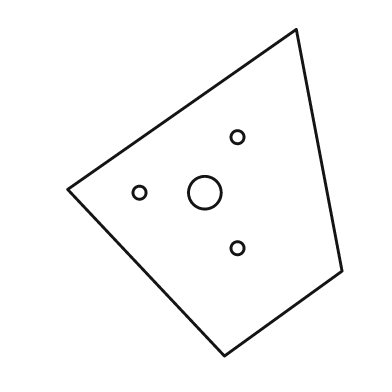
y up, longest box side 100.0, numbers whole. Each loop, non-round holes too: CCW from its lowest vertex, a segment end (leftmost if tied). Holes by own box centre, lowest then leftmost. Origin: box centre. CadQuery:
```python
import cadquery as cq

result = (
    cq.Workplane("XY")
    .moveTo(6.0, -50.0)
    .lineTo(42.0, -24.0)
    .lineTo(28.0, 50.0)
    .lineTo(-42.0, 1.0)
    .close()
    .moveTo(10.0, -17.0)
    .circle(2.0)
    .moveTo(-20.0, 0.0)
    .circle(2.0)
    .moveTo(0.0, 0.0)
    .circle(5.0)
    .moveTo(10.0, 17.0)
    .circle(2.0)
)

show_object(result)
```